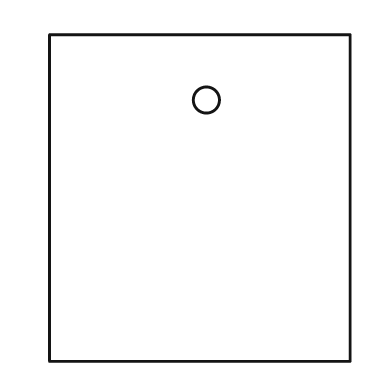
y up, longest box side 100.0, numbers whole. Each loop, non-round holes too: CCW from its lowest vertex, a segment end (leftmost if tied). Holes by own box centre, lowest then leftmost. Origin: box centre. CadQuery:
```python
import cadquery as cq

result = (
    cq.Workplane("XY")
    .moveTo(-46.0, -50.0)
    .lineTo(46.0, -50.0)
    .lineTo(46.0, 50.0)
    .lineTo(-46.0, 50.0)
    .close()
    .moveTo(2.0, 30.0)
    .circle(4.0)
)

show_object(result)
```